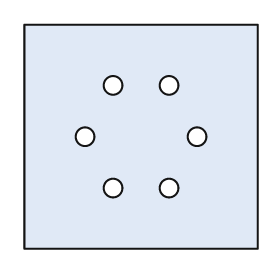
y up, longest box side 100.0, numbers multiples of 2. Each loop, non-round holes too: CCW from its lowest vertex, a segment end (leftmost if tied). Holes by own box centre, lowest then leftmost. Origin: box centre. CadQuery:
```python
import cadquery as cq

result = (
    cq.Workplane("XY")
    .moveTo(-50.0, -48.0)
    .lineTo(50.0, -48.0)
    .lineTo(50.0, 48.0)
    .lineTo(-50.0, 48.0)
    .close()
    .moveTo(-12.0, -22.0)
    .circle(4.0)
    .moveTo(12.0, -22.0)
    .circle(4.0)
    .moveTo(-24.0, 0.0)
    .circle(4.0)
    .moveTo(24.0, 0.0)
    .circle(4.0)
    .moveTo(-12.0, 22.0)
    .circle(4.0)
    .moveTo(12.0, 22.0)
    .circle(4.0)
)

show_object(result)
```